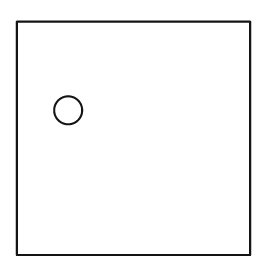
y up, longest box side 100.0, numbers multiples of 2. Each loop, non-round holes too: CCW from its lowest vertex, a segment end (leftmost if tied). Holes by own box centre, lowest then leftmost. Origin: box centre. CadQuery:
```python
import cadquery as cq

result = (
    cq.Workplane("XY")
    .moveTo(-50.0, -50.0)
    .lineTo(50.0, -50.0)
    .lineTo(50.0, 50.0)
    .lineTo(-50.0, 50.0)
    .close()
    .moveTo(-28.0, 12.0)
    .circle(6.0)
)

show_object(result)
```